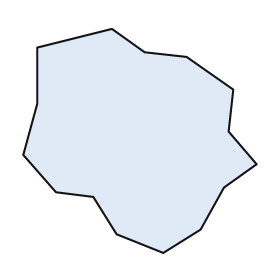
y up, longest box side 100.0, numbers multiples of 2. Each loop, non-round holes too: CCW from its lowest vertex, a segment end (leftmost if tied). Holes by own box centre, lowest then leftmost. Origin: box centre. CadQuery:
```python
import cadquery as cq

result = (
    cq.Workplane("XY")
    .moveTo(10.0, -48.0)
    .lineTo(26.0, -38.0)
    .lineTo(36.0, -20.0)
    .lineTo(50.0, -10.0)
    .lineTo(38.0, 4.0)
    .lineTo(40.0, 22.0)
    .lineTo(20.0, 36.0)
    .lineTo(2.0, 38.0)
    .lineTo(-12.0, 48.0)
    .lineTo(-44.0, 40.0)
    .lineTo(-44.0, 16.0)
    .lineTo(-50.0, -6.0)
    .lineTo(-36.0, -22.0)
    .lineTo(-20.0, -24.0)
    .lineTo(-10.0, -40.0)
    .close()
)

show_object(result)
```